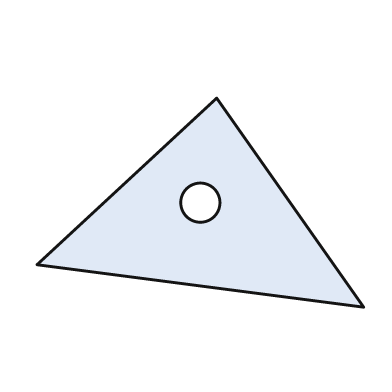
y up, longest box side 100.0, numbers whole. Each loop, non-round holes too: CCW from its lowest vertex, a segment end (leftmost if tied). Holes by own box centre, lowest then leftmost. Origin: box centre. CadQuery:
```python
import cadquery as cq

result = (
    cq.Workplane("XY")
    .moveTo(50.0, -32.0)
    .lineTo(5.0, 32.0)
    .lineTo(-50.0, -19.0)
    .close()
    .moveTo(0.0, 0.0)
    .circle(6.0)
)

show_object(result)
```